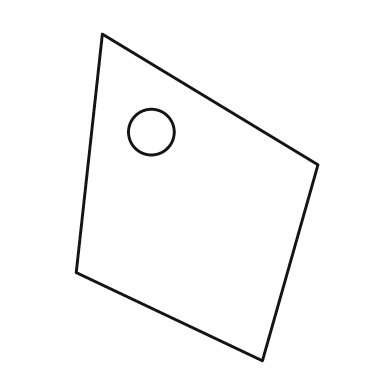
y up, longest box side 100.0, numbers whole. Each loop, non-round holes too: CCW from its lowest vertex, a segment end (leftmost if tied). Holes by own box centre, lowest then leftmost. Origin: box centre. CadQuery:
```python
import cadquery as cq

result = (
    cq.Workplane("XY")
    .moveTo(20.0, -50.0)
    .lineTo(37.0, 10.0)
    .lineTo(-29.0, 50.0)
    .lineTo(-37.0, -23.0)
    .close()
    .moveTo(-14.0, 20.0)
    .circle(7.0)
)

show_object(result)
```